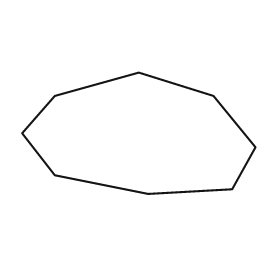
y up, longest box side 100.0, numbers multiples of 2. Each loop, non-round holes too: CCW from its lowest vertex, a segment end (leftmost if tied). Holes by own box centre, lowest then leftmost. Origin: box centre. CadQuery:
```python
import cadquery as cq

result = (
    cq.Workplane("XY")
    .moveTo(4.0, -26.0)
    .lineTo(40.0, -24.0)
    .lineTo(50.0, -6.0)
    .lineTo(32.0, 16.0)
    .lineTo(0.0, 26.0)
    .lineTo(-36.0, 16.0)
    .lineTo(-50.0, 0.0)
    .lineTo(-36.0, -18.0)
    .close()
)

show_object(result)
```